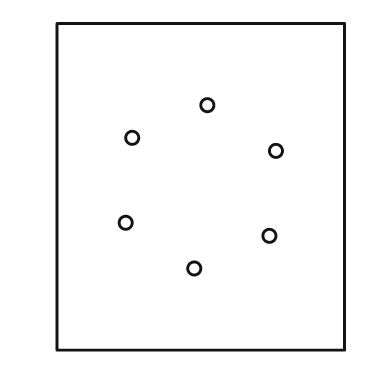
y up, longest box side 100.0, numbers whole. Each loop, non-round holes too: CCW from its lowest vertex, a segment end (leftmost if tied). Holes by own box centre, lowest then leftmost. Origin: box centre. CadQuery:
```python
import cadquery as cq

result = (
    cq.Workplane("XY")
    .moveTo(-44.0, -50.0)
    .lineTo(44.0, -50.0)
    .lineTo(44.0, 50.0)
    .lineTo(-44.0, 50.0)
    .close()
    .moveTo(-2.0, -25.0)
    .circle(2.0)
    .moveTo(21.0, -15.0)
    .circle(2.0)
    .moveTo(-23.0, -11.0)
    .circle(2.0)
    .moveTo(23.0, 11.0)
    .circle(2.0)
    .moveTo(-21.0, 15.0)
    .circle(2.0)
    .moveTo(2.0, 25.0)
    .circle(2.0)
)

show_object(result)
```